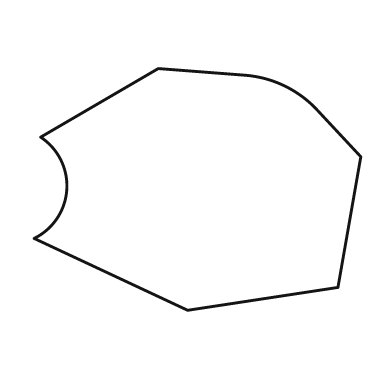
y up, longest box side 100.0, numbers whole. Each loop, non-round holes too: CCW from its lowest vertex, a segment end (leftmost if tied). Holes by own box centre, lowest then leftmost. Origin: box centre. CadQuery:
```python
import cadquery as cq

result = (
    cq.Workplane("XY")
    .moveTo(-3.0, -37.0)
    .lineTo(43.0, -30.0)
    .lineTo(50.0, 10.0)
    .lineTo(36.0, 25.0)
    .threePointArc((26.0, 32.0), (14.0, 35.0))
    .lineTo(-12.0, 37.0)
    .lineTo(-48.0, 16.0)
    .threePointArc((-40.0, 0.0), (-50.0, -15.0))
    .close()
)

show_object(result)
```